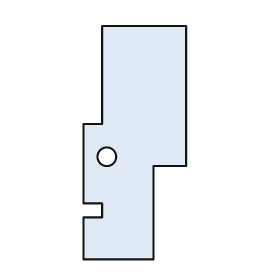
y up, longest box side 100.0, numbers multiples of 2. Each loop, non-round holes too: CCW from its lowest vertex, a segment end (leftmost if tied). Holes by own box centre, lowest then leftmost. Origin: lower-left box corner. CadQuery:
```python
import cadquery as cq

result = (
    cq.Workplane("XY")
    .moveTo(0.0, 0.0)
    .lineTo(30.0, 0.0)
    .lineTo(30.0, 40.0)
    .lineTo(44.0, 40.0)
    .lineTo(44.0, 100.0)
    .lineTo(8.0, 100.0)
    .lineTo(8.0, 58.0)
    .lineTo(0.0, 58.0)
    .lineTo(0.0, 24.0)
    .lineTo(8.0, 24.0)
    .lineTo(8.0, 18.0)
    .lineTo(0.0, 18.0)
    .close()
    .moveTo(10.0, 44.0)
    .circle(4.0)
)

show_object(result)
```